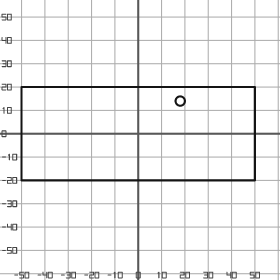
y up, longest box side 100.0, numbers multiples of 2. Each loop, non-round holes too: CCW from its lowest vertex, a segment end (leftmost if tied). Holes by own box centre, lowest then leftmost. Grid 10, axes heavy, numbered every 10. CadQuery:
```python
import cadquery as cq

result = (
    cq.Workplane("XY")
    .moveTo(-50.0, -20.0)
    .lineTo(50.0, -20.0)
    .lineTo(50.0, 20.0)
    .lineTo(-50.0, 20.0)
    .close()
    .moveTo(18.0, 14.0)
    .circle(2.0)
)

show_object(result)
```